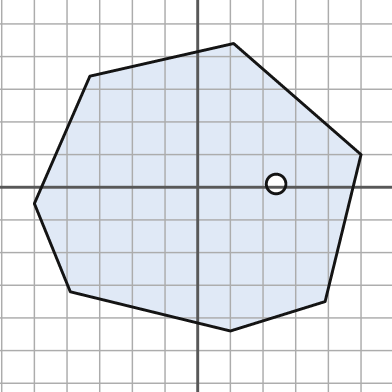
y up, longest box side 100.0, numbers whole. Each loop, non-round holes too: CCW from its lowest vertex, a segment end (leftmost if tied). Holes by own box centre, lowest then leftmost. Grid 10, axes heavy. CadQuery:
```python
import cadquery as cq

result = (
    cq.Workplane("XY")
    .moveTo(10.0, -44.0)
    .lineTo(39.0, -35.0)
    .lineTo(50.0, 10.0)
    .lineTo(11.0, 44.0)
    .lineTo(-33.0, 34.0)
    .lineTo(-50.0, -5.0)
    .lineTo(-39.0, -32.0)
    .close()
    .moveTo(24.0, 1.0)
    .circle(3.0)
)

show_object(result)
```